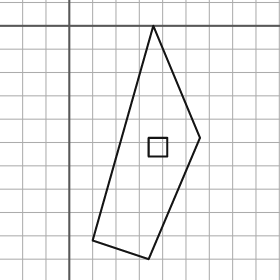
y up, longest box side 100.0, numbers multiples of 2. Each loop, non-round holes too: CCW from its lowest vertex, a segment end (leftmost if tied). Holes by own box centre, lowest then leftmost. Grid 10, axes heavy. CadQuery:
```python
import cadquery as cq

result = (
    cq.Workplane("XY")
    .moveTo(34.0, -100.0)
    .lineTo(56.0, -48.0)
    .lineTo(36.0, 0.0)
    .lineTo(10.0, -92.0)
    .close()
    .moveTo(34.0, -56.0)
    .lineTo(42.0, -56.0)
    .lineTo(42.0, -48.0)
    .lineTo(34.0, -48.0)
    .close()
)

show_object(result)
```